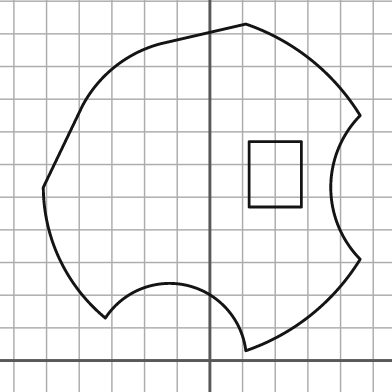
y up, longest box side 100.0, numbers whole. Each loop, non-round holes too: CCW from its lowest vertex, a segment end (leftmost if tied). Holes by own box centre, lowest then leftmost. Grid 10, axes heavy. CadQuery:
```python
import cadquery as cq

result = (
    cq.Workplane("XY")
    .moveTo(11.0, 3.0)
    .threePointArc((31.0, 14.0), (46.0, 31.0))
    .threePointArc((37.0, 53.0), (46.0, 75.0))
    .threePointArc((31.0, 92.0), (11.0, 103.0))
    .lineTo(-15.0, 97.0)
    .threePointArc((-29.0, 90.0), (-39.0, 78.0))
    .lineTo(-51.0, 53.0)
    .threePointArc((-46.0, 31.0), (-32.0, 13.0))
    .threePointArc((-7.0, 23.0), (11.0, 3.0))
    .close()
    .moveTo(12.0, 47.0)
    .lineTo(28.0, 47.0)
    .lineTo(28.0, 67.0)
    .lineTo(12.0, 67.0)
    .close()
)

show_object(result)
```